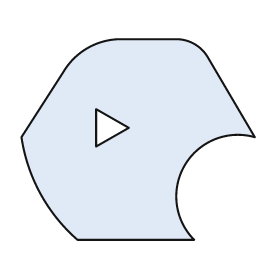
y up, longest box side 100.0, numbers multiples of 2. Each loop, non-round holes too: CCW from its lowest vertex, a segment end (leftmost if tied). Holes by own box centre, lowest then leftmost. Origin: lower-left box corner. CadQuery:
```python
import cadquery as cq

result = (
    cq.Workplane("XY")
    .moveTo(24.0, 0.0)
    .lineTo(74.0, 0.0)
    .threePointArc((70.0, 32.0), (100.0, 44.0))
    .lineTo(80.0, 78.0)
    .threePointArc((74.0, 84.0), (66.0, 86.0))
    .lineTo(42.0, 86.0)
    .threePointArc((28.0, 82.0), (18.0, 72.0))
    .lineTo(0.0, 44.0)
    .threePointArc((8.0, 20.0), (24.0, 0.0))
    .close()
    .moveTo(32.0, 40.0)
    .lineTo(46.0, 48.0)
    .lineTo(32.0, 56.0)
    .close()
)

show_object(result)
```